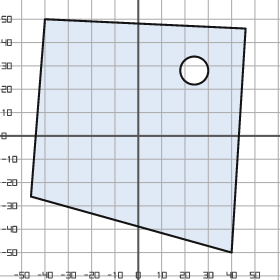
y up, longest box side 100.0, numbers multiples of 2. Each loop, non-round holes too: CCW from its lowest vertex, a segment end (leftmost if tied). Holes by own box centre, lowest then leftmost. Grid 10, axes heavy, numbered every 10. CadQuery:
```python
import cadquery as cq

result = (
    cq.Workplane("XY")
    .moveTo(40.0, -50.0)
    .lineTo(46.0, 46.0)
    .lineTo(-40.0, 50.0)
    .lineTo(-46.0, -26.0)
    .close()
    .moveTo(24.0, 28.0)
    .circle(6.0)
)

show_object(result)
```